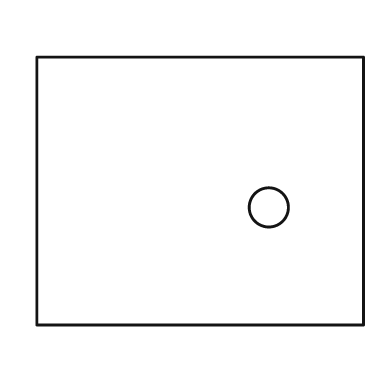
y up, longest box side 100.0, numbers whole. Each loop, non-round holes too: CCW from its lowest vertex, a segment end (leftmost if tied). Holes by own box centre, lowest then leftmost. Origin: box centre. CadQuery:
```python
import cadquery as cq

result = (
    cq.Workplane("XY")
    .moveTo(-50.0, -41.0)
    .lineTo(50.0, -41.0)
    .lineTo(50.0, 41.0)
    .lineTo(-50.0, 41.0)
    .close()
    .moveTo(21.0, -5.0)
    .circle(6.0)
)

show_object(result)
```